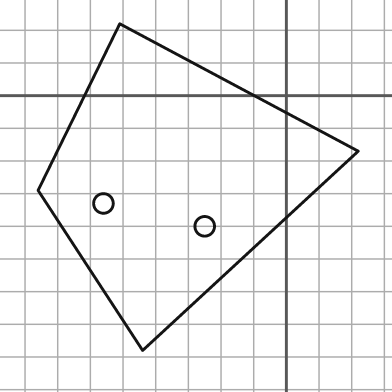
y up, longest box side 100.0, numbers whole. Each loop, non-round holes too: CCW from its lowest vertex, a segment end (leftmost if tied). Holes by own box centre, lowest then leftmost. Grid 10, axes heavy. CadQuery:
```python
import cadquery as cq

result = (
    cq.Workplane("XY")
    .moveTo(-44.0, -78.0)
    .lineTo(22.0, -17.0)
    .lineTo(-51.0, 22.0)
    .lineTo(-76.0, -29.0)
    .close()
    .moveTo(-25.0, -40.0)
    .circle(3.0)
    .moveTo(-56.0, -33.0)
    .circle(3.0)
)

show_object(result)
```